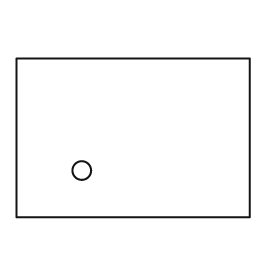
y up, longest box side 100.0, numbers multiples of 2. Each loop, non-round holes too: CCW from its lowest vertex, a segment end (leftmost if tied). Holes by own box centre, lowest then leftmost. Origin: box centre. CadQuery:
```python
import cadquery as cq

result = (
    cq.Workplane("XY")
    .moveTo(-50.0, -34.0)
    .lineTo(50.0, -34.0)
    .lineTo(50.0, 34.0)
    .lineTo(-50.0, 34.0)
    .close()
    .moveTo(-22.0, -14.0)
    .circle(4.0)
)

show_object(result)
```